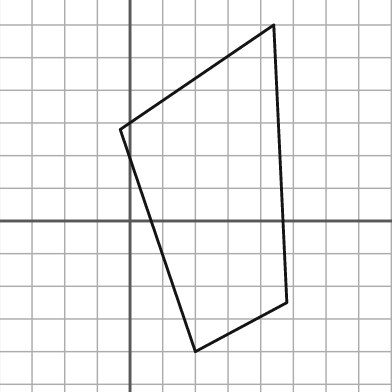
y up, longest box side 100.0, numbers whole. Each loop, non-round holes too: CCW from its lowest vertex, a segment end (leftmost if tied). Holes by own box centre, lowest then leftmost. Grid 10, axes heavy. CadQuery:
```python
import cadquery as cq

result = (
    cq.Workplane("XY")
    .moveTo(20.0, -40.0)
    .lineTo(48.0, -25.0)
    .lineTo(44.0, 60.0)
    .lineTo(-3.0, 28.0)
    .close()
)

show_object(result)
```